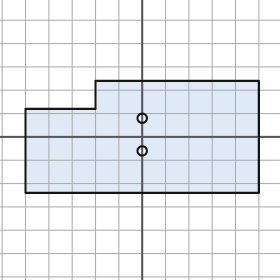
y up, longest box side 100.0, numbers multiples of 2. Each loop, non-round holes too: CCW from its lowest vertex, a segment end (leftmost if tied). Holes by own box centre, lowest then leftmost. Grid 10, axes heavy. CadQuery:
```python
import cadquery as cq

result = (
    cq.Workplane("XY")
    .moveTo(-50.0, -24.0)
    .lineTo(50.0, -24.0)
    .lineTo(50.0, 24.0)
    .lineTo(-20.0, 24.0)
    .lineTo(-20.0, 12.0)
    .lineTo(-50.0, 12.0)
    .close()
    .moveTo(0.0, -6.0)
    .circle(2.0)
    .moveTo(0.0, 8.0)
    .circle(2.0)
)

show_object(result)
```